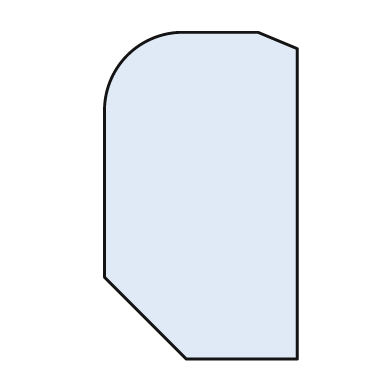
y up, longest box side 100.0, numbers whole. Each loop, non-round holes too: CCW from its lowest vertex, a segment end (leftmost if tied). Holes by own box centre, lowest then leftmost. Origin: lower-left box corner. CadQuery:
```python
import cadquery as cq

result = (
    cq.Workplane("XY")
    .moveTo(25.0, 0.0)
    .lineTo(59.0, 0.0)
    .lineTo(59.0, 95.0)
    .lineTo(47.0, 100.0)
    .lineTo(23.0, 100.0)
    .threePointArc((7.0, 93.0), (0.0, 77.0))
    .lineTo(0.0, 25.0)
    .close()
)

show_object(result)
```